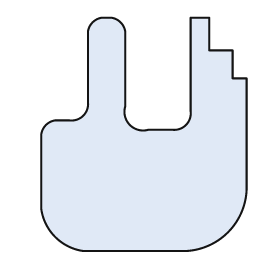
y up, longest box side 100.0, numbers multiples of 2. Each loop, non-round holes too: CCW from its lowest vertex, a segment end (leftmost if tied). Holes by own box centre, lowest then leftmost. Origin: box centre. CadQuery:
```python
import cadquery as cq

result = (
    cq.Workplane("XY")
    .moveTo(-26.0, -50.0)
    .lineTo(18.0, -50.0)
    .threePointArc((36.0, -42.0), (44.0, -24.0))
    .lineTo(44.0, 24.0)
    .lineTo(38.0, 24.0)
    .lineTo(38.0, 36.0)
    .lineTo(28.0, 36.0)
    .lineTo(28.0, 50.0)
    .lineTo(20.0, 50.0)
    .lineTo(20.0, 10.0)
    .threePointArc((18.0, 4.0), (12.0, 2.0))
    .lineTo(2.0, 2.0)
    .threePointArc((-6.0, 4.0), (-8.0, 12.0))
    .lineTo(-8.0, 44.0)
    .threePointArc((-10.0, 48.0), (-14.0, 50.0))
    .lineTo(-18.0, 50.0)
    .threePointArc((-22.0, 48.0), (-24.0, 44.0))
    .lineTo(-24.0, 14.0)
    .threePointArc((-26.0, 8.0), (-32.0, 6.0))
    .lineTo(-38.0, 6.0)
    .threePointArc((-42.0, 4.0), (-44.0, 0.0))
    .lineTo(-44.0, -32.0)
    .threePointArc((-38.0, -44.0), (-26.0, -50.0))
    .close()
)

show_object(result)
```